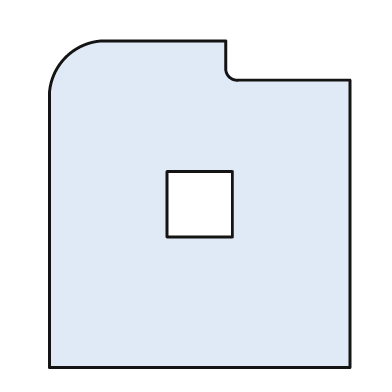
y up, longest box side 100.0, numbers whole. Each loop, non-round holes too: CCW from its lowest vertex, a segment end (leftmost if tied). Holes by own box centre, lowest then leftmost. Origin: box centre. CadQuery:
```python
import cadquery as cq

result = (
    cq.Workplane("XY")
    .moveTo(-46.0, -50.0)
    .lineTo(46.0, -50.0)
    .lineTo(46.0, 38.0)
    .lineTo(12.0, 38.0)
    .threePointArc((9.0, 39.0), (8.0, 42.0))
    .lineTo(8.0, 50.0)
    .lineTo(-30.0, 50.0)
    .threePointArc((-41.0, 45.0), (-46.0, 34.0))
    .close()
    .moveTo(-10.0, -10.0)
    .lineTo(10.0, -10.0)
    .lineTo(10.0, 10.0)
    .lineTo(-10.0, 10.0)
    .close()
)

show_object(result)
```